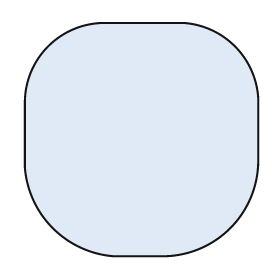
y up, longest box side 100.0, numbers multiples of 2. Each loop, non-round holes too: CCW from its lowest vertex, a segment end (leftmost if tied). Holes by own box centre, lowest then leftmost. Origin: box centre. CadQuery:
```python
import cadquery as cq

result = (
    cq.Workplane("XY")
    .moveTo(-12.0, -50.0)
    .lineTo(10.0, -50.0)
    .threePointArc((38.0, -38.0), (50.0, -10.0))
    .lineTo(50.0, 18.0)
    .threePointArc((40.0, 40.0), (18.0, 50.0))
    .lineTo(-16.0, 50.0)
    .threePointArc((-40.0, 40.0), (-50.0, 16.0))
    .lineTo(-50.0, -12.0)
    .threePointArc((-38.0, -38.0), (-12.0, -50.0))
    .close()
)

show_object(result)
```